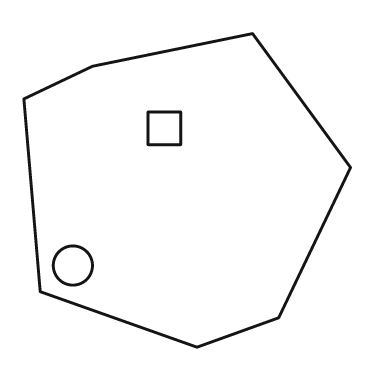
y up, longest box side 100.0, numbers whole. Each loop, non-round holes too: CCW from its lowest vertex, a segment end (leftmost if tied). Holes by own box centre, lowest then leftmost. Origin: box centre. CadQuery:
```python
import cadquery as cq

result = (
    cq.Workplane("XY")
    .moveTo(3.0, -48.0)
    .lineTo(28.0, -39.0)
    .lineTo(50.0, 7.0)
    .lineTo(20.0, 48.0)
    .lineTo(-29.0, 38.0)
    .lineTo(-50.0, 28.0)
    .lineTo(-45.0, -31.0)
    .close()
    .moveTo(-35.0, -23.0)
    .circle(6.0)
    .moveTo(-12.0, 14.0)
    .lineTo(-2.0, 14.0)
    .lineTo(-2.0, 24.0)
    .lineTo(-12.0, 24.0)
    .close()
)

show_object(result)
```